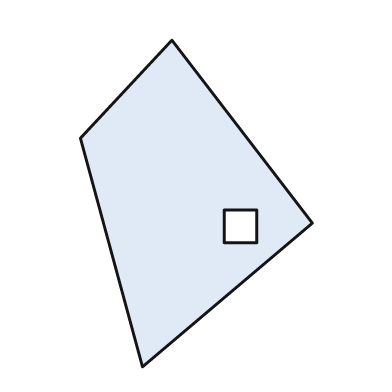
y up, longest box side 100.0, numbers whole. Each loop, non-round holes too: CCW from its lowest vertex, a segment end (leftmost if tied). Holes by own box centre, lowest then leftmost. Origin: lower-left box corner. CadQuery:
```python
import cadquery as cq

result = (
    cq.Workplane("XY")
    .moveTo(19.0, 0.0)
    .lineTo(71.0, 44.0)
    .lineTo(28.0, 100.0)
    .lineTo(0.0, 70.0)
    .close()
    .moveTo(44.0, 38.0)
    .lineTo(54.0, 38.0)
    .lineTo(54.0, 48.0)
    .lineTo(44.0, 48.0)
    .close()
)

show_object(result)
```